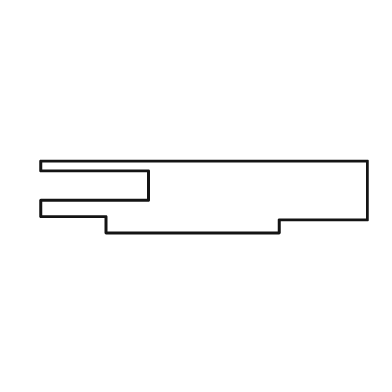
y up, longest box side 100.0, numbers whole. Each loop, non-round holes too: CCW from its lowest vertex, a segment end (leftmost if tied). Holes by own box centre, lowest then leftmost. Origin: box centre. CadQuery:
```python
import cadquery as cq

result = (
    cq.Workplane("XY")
    .moveTo(-30.0, -11.0)
    .lineTo(23.0, -11.0)
    .lineTo(23.0, -7.0)
    .lineTo(50.0, -7.0)
    .lineTo(50.0, 11.0)
    .lineTo(-50.0, 11.0)
    .lineTo(-50.0, 8.0)
    .lineTo(-17.0, 8.0)
    .lineTo(-17.0, -1.0)
    .lineTo(-50.0, -1.0)
    .lineTo(-50.0, -6.0)
    .lineTo(-30.0, -6.0)
    .close()
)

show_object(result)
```